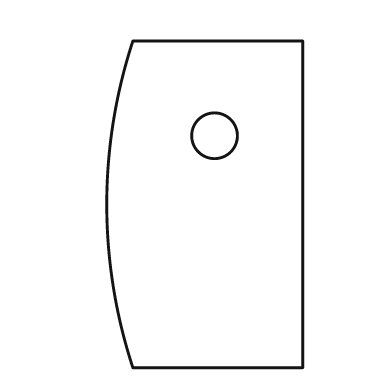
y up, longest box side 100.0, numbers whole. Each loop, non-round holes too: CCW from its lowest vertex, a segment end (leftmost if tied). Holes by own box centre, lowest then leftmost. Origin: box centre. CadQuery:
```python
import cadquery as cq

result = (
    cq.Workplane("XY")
    .moveTo(-22.0, -50.0)
    .lineTo(30.0, -50.0)
    .lineTo(30.0, 50.0)
    .lineTo(-22.0, 50.0)
    .threePointArc((-30.0, 0.0), (-22.0, -50.0))
    .close()
    .moveTo(3.0, 21.0)
    .circle(7.0)
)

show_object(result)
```